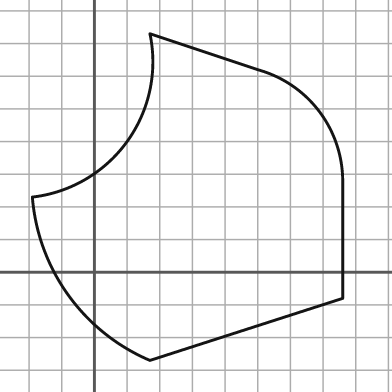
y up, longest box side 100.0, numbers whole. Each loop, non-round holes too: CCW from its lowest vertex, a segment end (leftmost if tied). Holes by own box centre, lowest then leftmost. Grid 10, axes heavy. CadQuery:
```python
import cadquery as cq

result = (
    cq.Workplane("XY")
    .moveTo(17.0, -27.0)
    .lineTo(76.0, -8.0)
    .lineTo(76.0, 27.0)
    .threePointArc((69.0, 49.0), (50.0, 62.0))
    .lineTo(17.0, 73.0)
    .threePointArc((10.0, 40.0), (-19.0, 23.0))
    .threePointArc((-8.0, -7.0), (17.0, -27.0))
    .close()
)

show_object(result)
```